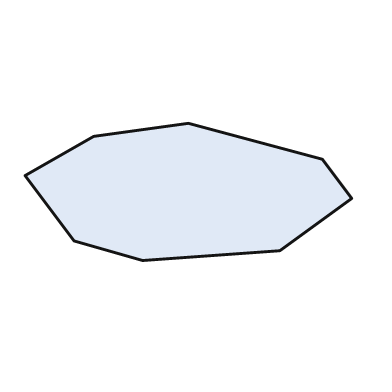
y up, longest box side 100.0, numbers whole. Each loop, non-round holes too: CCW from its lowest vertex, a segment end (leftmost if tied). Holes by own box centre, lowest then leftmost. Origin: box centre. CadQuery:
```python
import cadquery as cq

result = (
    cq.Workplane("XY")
    .moveTo(-14.0, -21.0)
    .lineTo(28.0, -18.0)
    .lineTo(50.0, -2.0)
    .lineTo(41.0, 10.0)
    .lineTo(0.0, 21.0)
    .lineTo(-29.0, 17.0)
    .lineTo(-50.0, 5.0)
    .lineTo(-35.0, -15.0)
    .close()
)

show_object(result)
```